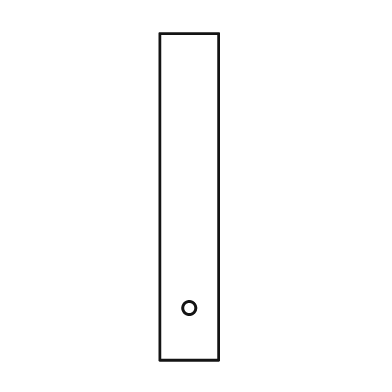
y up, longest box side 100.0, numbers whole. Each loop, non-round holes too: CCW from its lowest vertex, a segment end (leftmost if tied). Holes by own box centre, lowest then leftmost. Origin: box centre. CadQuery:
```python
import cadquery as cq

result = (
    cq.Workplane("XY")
    .moveTo(-9.0, -50.0)
    .lineTo(9.0, -50.0)
    .lineTo(9.0, 50.0)
    .lineTo(-9.0, 50.0)
    .close()
    .moveTo(0.0, -34.0)
    .circle(2.0)
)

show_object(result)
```